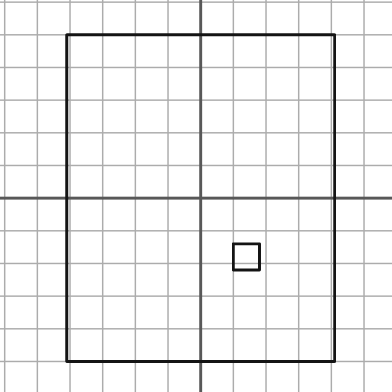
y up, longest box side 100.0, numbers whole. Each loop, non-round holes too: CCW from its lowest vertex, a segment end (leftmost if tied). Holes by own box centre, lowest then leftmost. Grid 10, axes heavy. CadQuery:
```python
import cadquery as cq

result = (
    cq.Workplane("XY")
    .moveTo(-41.0, -50.0)
    .lineTo(41.0, -50.0)
    .lineTo(41.0, 50.0)
    .lineTo(-41.0, 50.0)
    .close()
    .moveTo(10.0, -22.0)
    .lineTo(18.0, -22.0)
    .lineTo(18.0, -14.0)
    .lineTo(10.0, -14.0)
    .close()
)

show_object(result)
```